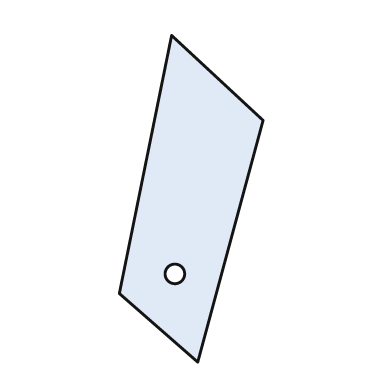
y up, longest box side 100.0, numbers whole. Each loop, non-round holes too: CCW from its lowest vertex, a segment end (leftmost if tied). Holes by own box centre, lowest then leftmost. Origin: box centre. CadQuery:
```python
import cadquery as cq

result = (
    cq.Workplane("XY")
    .moveTo(2.0, -50.0)
    .lineTo(22.0, 24.0)
    .lineTo(-6.0, 50.0)
    .lineTo(-22.0, -29.0)
    .close()
    .moveTo(-5.0, -23.0)
    .circle(3.0)
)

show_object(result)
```